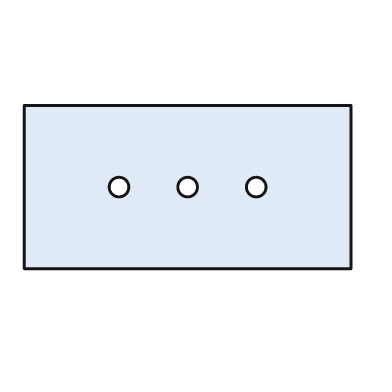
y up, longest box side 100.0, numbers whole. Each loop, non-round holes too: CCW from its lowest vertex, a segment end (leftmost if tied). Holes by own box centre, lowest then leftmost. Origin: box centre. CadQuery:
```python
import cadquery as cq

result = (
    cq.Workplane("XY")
    .moveTo(-50.0, -25.0)
    .lineTo(50.0, -25.0)
    .lineTo(50.0, 25.0)
    .lineTo(-50.0, 25.0)
    .close()
    .moveTo(-21.0, 0.0)
    .circle(3.0)
    .moveTo(0.0, 0.0)
    .circle(3.0)
    .moveTo(21.0, 0.0)
    .circle(3.0)
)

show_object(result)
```